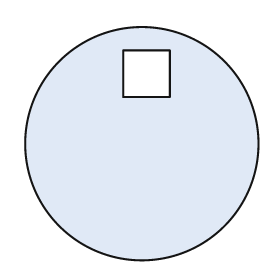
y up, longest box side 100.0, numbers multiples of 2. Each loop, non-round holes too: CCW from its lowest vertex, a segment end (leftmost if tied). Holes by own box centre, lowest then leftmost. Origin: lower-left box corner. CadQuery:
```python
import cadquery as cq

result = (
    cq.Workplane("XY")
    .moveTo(50.0, 50.0)
    .circle(50.0)
    .moveTo(42.0, 70.0)
    .lineTo(62.0, 70.0)
    .lineTo(62.0, 90.0)
    .lineTo(42.0, 90.0)
    .close()
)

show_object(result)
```